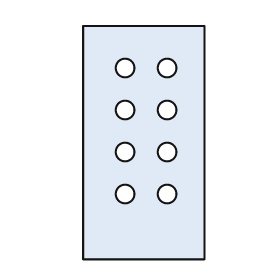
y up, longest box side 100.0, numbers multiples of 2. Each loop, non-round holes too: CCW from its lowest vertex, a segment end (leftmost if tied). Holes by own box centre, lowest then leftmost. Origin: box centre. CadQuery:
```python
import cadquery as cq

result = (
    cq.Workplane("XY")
    .moveTo(-26.0, -50.0)
    .lineTo(26.0, -50.0)
    .lineTo(26.0, 50.0)
    .lineTo(-26.0, 50.0)
    .close()
    .moveTo(-8.0, -22.0)
    .circle(4.0)
    .moveTo(10.0, -22.0)
    .circle(4.0)
    .moveTo(-8.0, -4.0)
    .circle(4.0)
    .moveTo(10.0, -4.0)
    .circle(4.0)
    .moveTo(-8.0, 14.0)
    .circle(4.0)
    .moveTo(10.0, 14.0)
    .circle(4.0)
    .moveTo(-8.0, 32.0)
    .circle(4.0)
    .moveTo(10.0, 32.0)
    .circle(4.0)
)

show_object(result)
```